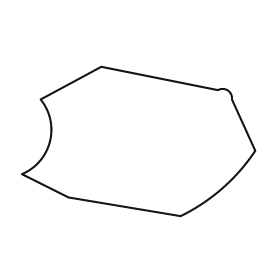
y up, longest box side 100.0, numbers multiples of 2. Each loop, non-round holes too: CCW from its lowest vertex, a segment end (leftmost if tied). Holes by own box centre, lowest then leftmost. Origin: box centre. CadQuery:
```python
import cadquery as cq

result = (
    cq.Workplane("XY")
    .moveTo(18.0, -32.0)
    .threePointArc((36.0, -20.0), (50.0, -4.0))
    .lineTo(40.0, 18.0)
    .threePointArc((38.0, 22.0), (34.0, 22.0))
    .lineTo(-16.0, 32.0)
    .lineTo(-42.0, 18.0)
    .threePointArc((-38.0, 0.0), (-50.0, -14.0))
    .lineTo(-30.0, -24.0)
    .close()
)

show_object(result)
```